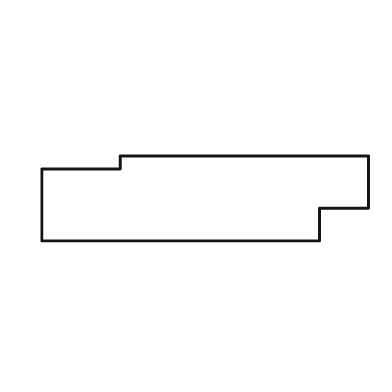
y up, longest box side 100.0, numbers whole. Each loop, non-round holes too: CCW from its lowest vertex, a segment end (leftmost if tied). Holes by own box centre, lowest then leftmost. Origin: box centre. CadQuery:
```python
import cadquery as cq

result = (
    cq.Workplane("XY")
    .moveTo(-50.0, -13.0)
    .lineTo(35.0, -13.0)
    .lineTo(35.0, -3.0)
    .lineTo(50.0, -3.0)
    .lineTo(50.0, 13.0)
    .lineTo(-26.0, 13.0)
    .lineTo(-26.0, 9.0)
    .lineTo(-50.0, 9.0)
    .close()
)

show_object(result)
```